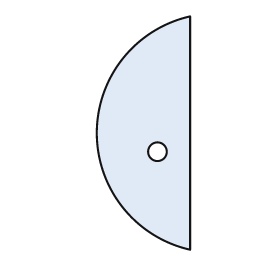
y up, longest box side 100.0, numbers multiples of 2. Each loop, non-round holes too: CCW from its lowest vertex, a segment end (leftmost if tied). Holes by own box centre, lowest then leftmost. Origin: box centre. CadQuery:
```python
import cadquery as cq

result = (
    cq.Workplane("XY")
    .moveTo(20.0, -50.0)
    .lineTo(20.0, 50.0)
    .threePointArc((-20.0, 0.0), (20.0, -50.0))
    .close()
    .moveTo(6.0, -8.0)
    .circle(4.0)
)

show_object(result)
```